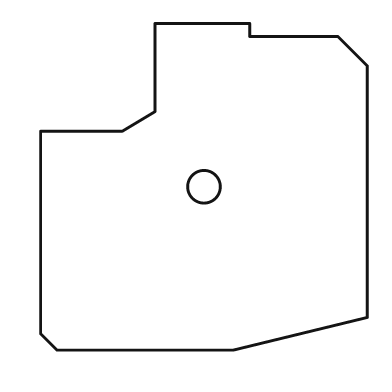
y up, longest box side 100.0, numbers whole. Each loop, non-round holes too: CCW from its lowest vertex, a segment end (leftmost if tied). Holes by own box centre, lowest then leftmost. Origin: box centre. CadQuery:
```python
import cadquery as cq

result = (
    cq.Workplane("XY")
    .moveTo(-45.0, -50.0)
    .lineTo(9.0, -50.0)
    .lineTo(50.0, -40.0)
    .lineTo(50.0, 37.0)
    .lineTo(41.0, 46.0)
    .lineTo(14.0, 46.0)
    .lineTo(14.0, 50.0)
    .lineTo(-15.0, 50.0)
    .lineTo(-15.0, 23.0)
    .lineTo(-25.0, 17.0)
    .lineTo(-50.0, 17.0)
    .lineTo(-50.0, -45.0)
    .close()
    .moveTo(0.0, 0.0)
    .circle(5.0)
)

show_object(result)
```